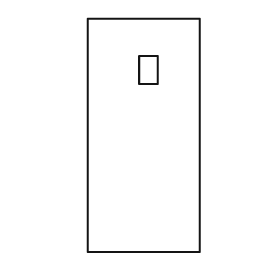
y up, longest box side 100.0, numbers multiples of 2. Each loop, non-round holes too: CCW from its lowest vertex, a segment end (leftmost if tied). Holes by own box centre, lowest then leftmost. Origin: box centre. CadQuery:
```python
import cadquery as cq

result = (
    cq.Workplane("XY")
    .moveTo(-24.0, -50.0)
    .lineTo(24.0, -50.0)
    .lineTo(24.0, 50.0)
    .lineTo(-24.0, 50.0)
    .close()
    .moveTo(-2.0, 22.0)
    .lineTo(6.0, 22.0)
    .lineTo(6.0, 34.0)
    .lineTo(-2.0, 34.0)
    .close()
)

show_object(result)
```